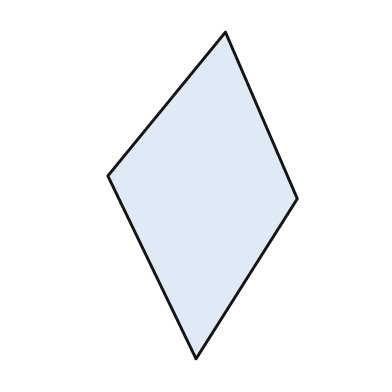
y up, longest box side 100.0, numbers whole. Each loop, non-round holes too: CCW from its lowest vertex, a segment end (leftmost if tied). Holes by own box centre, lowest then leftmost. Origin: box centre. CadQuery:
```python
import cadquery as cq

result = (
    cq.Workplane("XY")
    .moveTo(-2.0, -50.0)
    .lineTo(29.0, -1.0)
    .lineTo(7.0, 50.0)
    .lineTo(-29.0, 6.0)
    .close()
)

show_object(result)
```